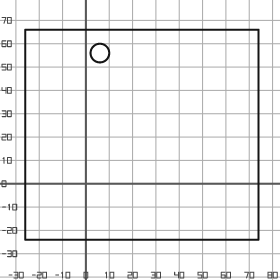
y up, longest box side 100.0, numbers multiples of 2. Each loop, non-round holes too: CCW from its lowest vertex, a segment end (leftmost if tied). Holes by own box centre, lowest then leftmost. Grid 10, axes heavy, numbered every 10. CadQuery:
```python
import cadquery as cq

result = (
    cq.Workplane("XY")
    .moveTo(-26.0, -24.0)
    .lineTo(74.0, -24.0)
    .lineTo(74.0, 66.0)
    .lineTo(-26.0, 66.0)
    .close()
    .moveTo(6.0, 56.0)
    .circle(4.0)
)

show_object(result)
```